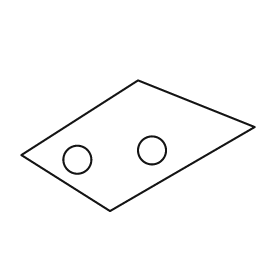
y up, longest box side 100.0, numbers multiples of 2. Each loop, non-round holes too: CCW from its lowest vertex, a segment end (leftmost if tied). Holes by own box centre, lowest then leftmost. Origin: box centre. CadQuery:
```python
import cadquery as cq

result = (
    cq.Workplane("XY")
    .moveTo(-12.0, -28.0)
    .lineTo(50.0, 8.0)
    .lineTo(0.0, 28.0)
    .lineTo(-50.0, -4.0)
    .close()
    .moveTo(-26.0, -6.0)
    .circle(6.0)
    .moveTo(6.0, -2.0)
    .circle(6.0)
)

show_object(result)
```